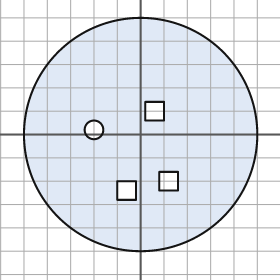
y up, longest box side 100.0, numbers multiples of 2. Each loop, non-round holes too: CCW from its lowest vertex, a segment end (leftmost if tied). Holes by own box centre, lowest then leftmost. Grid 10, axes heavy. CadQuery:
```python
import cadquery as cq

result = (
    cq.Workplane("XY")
    .moveTo(0.0, 0.0)
    .circle(50.0)
    .moveTo(-10.0, -28.0)
    .lineTo(-2.0, -28.0)
    .lineTo(-2.0, -20.0)
    .lineTo(-10.0, -20.0)
    .close()
    .moveTo(8.0, -24.0)
    .lineTo(16.0, -24.0)
    .lineTo(16.0, -16.0)
    .lineTo(8.0, -16.0)
    .close()
    .moveTo(-20.0, 2.0)
    .circle(4.0)
    .moveTo(2.0, 6.0)
    .lineTo(10.0, 6.0)
    .lineTo(10.0, 14.0)
    .lineTo(2.0, 14.0)
    .close()
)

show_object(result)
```